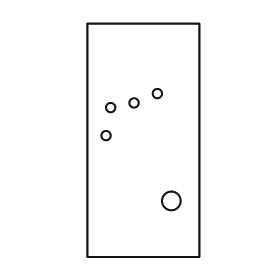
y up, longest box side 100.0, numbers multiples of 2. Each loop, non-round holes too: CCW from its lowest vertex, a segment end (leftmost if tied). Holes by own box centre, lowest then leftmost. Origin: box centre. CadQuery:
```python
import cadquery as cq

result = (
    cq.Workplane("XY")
    .moveTo(-24.0, -50.0)
    .lineTo(24.0, -50.0)
    .lineTo(24.0, 50.0)
    .lineTo(-24.0, 50.0)
    .close()
    .moveTo(12.0, -26.0)
    .circle(4.0)
    .moveTo(-16.0, 2.0)
    .circle(2.0)
    .moveTo(-14.0, 14.0)
    .circle(2.0)
    .moveTo(-4.0, 16.0)
    .circle(2.0)
    .moveTo(6.0, 20.0)
    .circle(2.0)
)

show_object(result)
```